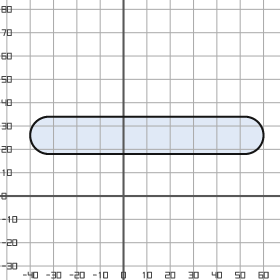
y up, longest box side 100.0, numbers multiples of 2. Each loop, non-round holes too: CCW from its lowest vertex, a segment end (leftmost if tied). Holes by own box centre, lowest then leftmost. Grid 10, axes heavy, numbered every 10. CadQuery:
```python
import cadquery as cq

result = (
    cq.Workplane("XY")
    .moveTo(-32.0, 18.0)
    .lineTo(52.0, 18.0)
    .threePointArc((60.0, 26.0), (52.0, 34.0))
    .lineTo(-32.0, 34.0)
    .threePointArc((-40.0, 26.0), (-32.0, 18.0))
    .close()
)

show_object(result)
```